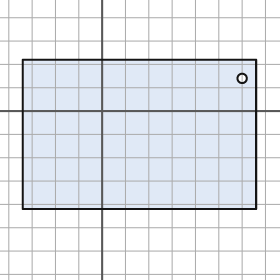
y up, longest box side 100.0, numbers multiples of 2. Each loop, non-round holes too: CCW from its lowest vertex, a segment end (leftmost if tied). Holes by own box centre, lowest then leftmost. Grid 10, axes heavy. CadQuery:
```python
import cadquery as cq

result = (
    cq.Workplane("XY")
    .moveTo(-34.0, -42.0)
    .lineTo(66.0, -42.0)
    .lineTo(66.0, 22.0)
    .lineTo(-34.0, 22.0)
    .close()
    .moveTo(60.0, 14.0)
    .circle(2.0)
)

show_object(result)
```